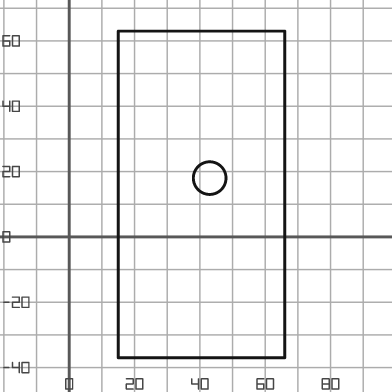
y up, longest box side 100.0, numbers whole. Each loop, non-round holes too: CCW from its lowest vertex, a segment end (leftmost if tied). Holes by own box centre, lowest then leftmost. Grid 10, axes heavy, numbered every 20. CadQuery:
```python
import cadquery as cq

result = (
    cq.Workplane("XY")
    .moveTo(15.0, -37.0)
    .lineTo(66.0, -37.0)
    .lineTo(66.0, 63.0)
    .lineTo(15.0, 63.0)
    .close()
    .moveTo(43.0, 18.0)
    .circle(5.0)
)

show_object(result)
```